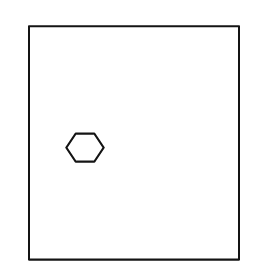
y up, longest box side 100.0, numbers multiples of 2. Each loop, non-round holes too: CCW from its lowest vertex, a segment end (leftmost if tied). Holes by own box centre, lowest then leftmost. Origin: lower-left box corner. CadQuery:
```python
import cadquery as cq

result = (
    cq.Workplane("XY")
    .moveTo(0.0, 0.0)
    .lineTo(90.0, 0.0)
    .lineTo(90.0, 100.0)
    .lineTo(0.0, 100.0)
    .close()
    .moveTo(20.0, 42.0)
    .lineTo(28.0, 42.0)
    .lineTo(32.0, 48.0)
    .lineTo(28.0, 54.0)
    .lineTo(20.0, 54.0)
    .lineTo(16.0, 48.0)
    .close()
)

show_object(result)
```